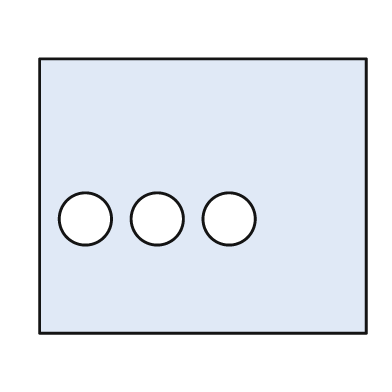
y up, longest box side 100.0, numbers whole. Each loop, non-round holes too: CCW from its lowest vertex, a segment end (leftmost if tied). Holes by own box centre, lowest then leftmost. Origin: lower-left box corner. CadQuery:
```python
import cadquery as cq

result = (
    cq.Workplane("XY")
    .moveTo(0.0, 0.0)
    .lineTo(100.0, 0.0)
    .lineTo(100.0, 84.0)
    .lineTo(0.0, 84.0)
    .close()
    .moveTo(14.0, 35.0)
    .circle(8.0)
    .moveTo(36.0, 35.0)
    .circle(8.0)
    .moveTo(58.0, 35.0)
    .circle(8.0)
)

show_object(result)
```